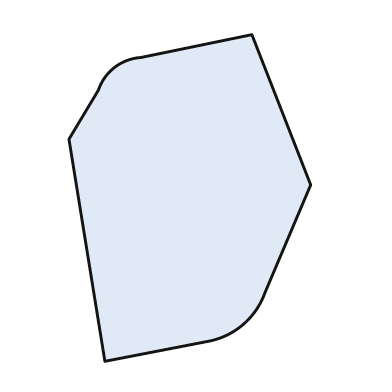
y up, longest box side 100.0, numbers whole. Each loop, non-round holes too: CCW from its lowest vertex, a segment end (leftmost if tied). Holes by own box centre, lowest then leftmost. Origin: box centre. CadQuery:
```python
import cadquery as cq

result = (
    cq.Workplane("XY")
    .moveTo(-26.0, -50.0)
    .lineTo(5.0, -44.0)
    .threePointArc((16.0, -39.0), (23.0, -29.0))
    .lineTo(37.0, 4.0)
    .lineTo(19.0, 50.0)
    .lineTo(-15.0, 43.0)
    .threePointArc((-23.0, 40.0), (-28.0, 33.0))
    .lineTo(-37.0, 18.0)
    .close()
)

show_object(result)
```